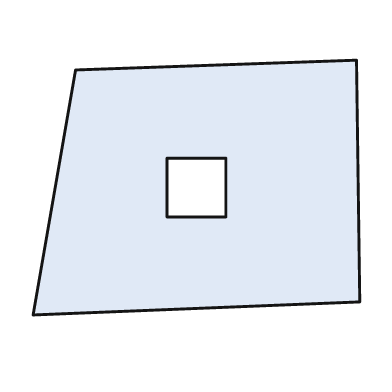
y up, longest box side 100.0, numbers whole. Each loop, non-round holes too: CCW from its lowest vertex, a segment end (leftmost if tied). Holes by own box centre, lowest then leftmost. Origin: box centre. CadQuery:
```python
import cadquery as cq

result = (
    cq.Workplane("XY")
    .moveTo(-50.0, -39.0)
    .lineTo(50.0, -35.0)
    .lineTo(49.0, 39.0)
    .lineTo(-37.0, 36.0)
    .close()
    .moveTo(-9.0, -9.0)
    .lineTo(9.0, -9.0)
    .lineTo(9.0, 9.0)
    .lineTo(-9.0, 9.0)
    .close()
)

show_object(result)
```